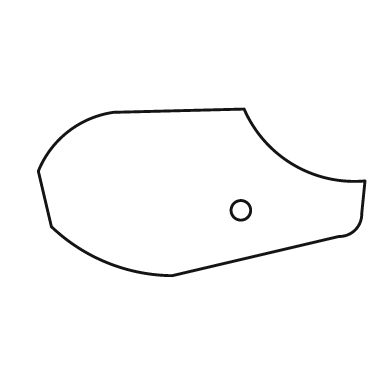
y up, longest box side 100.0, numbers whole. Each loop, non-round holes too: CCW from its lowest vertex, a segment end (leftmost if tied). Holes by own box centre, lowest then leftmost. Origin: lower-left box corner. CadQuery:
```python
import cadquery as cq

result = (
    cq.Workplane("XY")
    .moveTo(41.0, 0.0)
    .lineTo(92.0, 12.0)
    .threePointArc((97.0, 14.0), (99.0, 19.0))
    .lineTo(100.0, 29.0)
    .threePointArc((78.0, 34.0), (63.0, 51.0))
    .lineTo(23.0, 50.0)
    .threePointArc((9.0, 44.0), (0.0, 32.0))
    .lineTo(4.0, 15.0)
    .threePointArc((21.0, 4.0), (41.0, 0.0))
    .close()
    .moveTo(62.0, 20.0)
    .circle(3.0)
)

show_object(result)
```